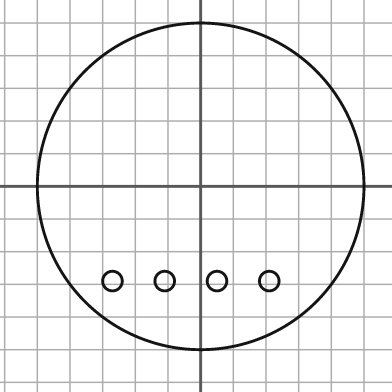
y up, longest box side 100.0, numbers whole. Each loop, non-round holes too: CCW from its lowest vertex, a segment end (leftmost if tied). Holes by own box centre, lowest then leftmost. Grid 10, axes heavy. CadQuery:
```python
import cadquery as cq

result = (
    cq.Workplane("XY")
    .moveTo(0.0, 0.0)
    .circle(50.0)
    .moveTo(-27.0, -29.0)
    .circle(3.0)
    .moveTo(-11.0, -29.0)
    .circle(3.0)
    .moveTo(5.0, -29.0)
    .circle(3.0)
    .moveTo(21.0, -29.0)
    .circle(3.0)
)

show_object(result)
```